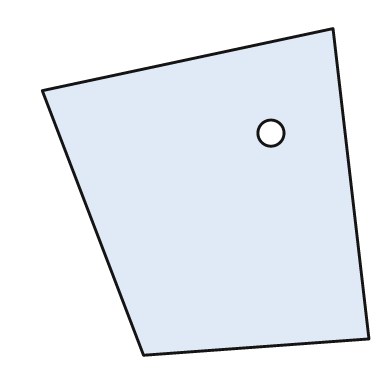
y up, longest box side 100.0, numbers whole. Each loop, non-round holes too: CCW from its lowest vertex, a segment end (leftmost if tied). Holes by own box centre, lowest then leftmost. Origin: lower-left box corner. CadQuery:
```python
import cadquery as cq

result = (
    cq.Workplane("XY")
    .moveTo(31.0, 0.0)
    .lineTo(100.0, 5.0)
    .lineTo(89.0, 100.0)
    .lineTo(0.0, 81.0)
    .close()
    .moveTo(70.0, 68.0)
    .circle(4.0)
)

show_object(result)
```